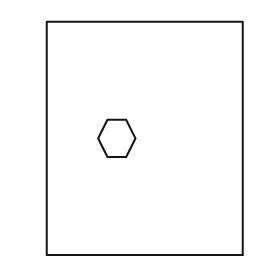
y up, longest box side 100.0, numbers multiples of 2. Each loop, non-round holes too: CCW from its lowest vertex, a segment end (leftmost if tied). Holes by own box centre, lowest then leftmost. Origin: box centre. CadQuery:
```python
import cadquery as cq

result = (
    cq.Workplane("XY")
    .moveTo(-42.0, -50.0)
    .lineTo(42.0, -50.0)
    .lineTo(42.0, 50.0)
    .lineTo(-42.0, 50.0)
    .close()
    .moveTo(-16.0, -8.0)
    .lineTo(-8.0, -8.0)
    .lineTo(-4.0, 0.0)
    .lineTo(-8.0, 8.0)
    .lineTo(-16.0, 8.0)
    .lineTo(-20.0, 0.0)
    .close()
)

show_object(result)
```